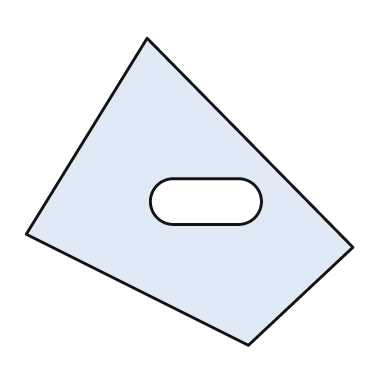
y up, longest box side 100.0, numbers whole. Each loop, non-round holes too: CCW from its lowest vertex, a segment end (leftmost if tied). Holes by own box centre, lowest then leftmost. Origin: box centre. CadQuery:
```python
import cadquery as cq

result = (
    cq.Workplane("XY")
    .moveTo(18.0, -47.0)
    .lineTo(50.0, -17.0)
    .lineTo(-13.0, 47.0)
    .lineTo(-50.0, -13.0)
    .close()
    .moveTo(-5.0, -10.0)
    .lineTo(15.0, -10.0)
    .threePointArc((22.0, -3.0), (15.0, 4.0))
    .lineTo(-5.0, 4.0)
    .threePointArc((-12.0, -3.0), (-5.0, -10.0))
    .close()
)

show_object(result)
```